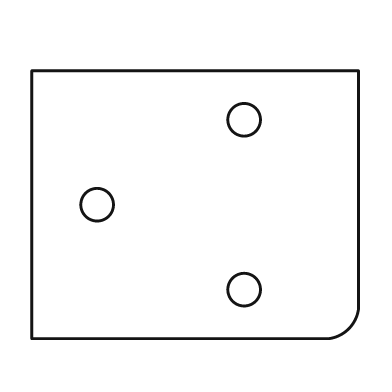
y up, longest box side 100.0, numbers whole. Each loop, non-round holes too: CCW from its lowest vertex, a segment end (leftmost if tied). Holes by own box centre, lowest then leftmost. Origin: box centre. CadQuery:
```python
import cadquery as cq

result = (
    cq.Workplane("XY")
    .moveTo(-50.0, -41.0)
    .lineTo(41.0, -41.0)
    .threePointArc((47.0, -38.0), (50.0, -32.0))
    .lineTo(50.0, 41.0)
    .lineTo(-50.0, 41.0)
    .close()
    .moveTo(15.0, -26.0)
    .circle(5.0)
    .moveTo(-30.0, 0.0)
    .circle(5.0)
    .moveTo(15.0, 26.0)
    .circle(5.0)
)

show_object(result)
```